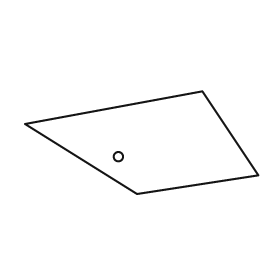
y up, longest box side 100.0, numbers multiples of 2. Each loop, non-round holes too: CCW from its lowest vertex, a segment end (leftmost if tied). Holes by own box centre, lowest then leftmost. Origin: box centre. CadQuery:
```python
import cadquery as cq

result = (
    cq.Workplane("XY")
    .moveTo(-2.0, -22.0)
    .lineTo(50.0, -14.0)
    .lineTo(26.0, 22.0)
    .lineTo(-50.0, 8.0)
    .close()
    .moveTo(-10.0, -6.0)
    .circle(2.0)
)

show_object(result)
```